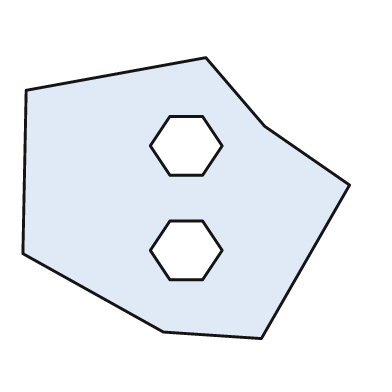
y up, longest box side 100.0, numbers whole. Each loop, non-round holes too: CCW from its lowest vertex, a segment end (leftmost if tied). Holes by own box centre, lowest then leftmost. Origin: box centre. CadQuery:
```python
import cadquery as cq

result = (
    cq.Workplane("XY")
    .moveTo(23.0, -43.0)
    .lineTo(50.0, 4.0)
    .lineTo(24.0, 22.0)
    .lineTo(6.0, 43.0)
    .lineTo(-49.0, 33.0)
    .lineTo(-50.0, -17.0)
    .lineTo(-7.0, -41.0)
    .close()
    .moveTo(-5.0, -25.0)
    .lineTo(5.0, -25.0)
    .lineTo(11.0, -16.0)
    .lineTo(5.0, -7.0)
    .lineTo(-5.0, -7.0)
    .lineTo(-11.0, -16.0)
    .close()
    .moveTo(-5.0, 7.0)
    .lineTo(5.0, 7.0)
    .lineTo(11.0, 16.0)
    .lineTo(5.0, 25.0)
    .lineTo(-5.0, 25.0)
    .lineTo(-11.0, 16.0)
    .close()
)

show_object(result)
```